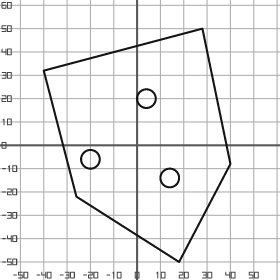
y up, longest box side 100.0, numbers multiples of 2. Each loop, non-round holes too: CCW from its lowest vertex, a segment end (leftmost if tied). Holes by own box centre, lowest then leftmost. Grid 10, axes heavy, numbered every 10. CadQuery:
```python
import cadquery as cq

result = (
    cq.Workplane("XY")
    .moveTo(18.0, -50.0)
    .lineTo(40.0, -8.0)
    .lineTo(28.0, 50.0)
    .lineTo(-40.0, 32.0)
    .lineTo(-26.0, -22.0)
    .close()
    .moveTo(14.0, -14.0)
    .circle(4.0)
    .moveTo(-20.0, -6.0)
    .circle(4.0)
    .moveTo(4.0, 20.0)
    .circle(4.0)
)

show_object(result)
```